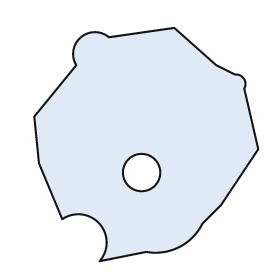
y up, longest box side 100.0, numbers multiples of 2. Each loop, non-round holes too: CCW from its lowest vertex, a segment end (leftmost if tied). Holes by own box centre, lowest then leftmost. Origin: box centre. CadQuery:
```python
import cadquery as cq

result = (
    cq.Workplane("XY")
    .moveTo(-20.0, -50.0)
    .lineTo(0.0, -46.0)
    .threePointArc((14.0, -44.0), (24.0, -34.0))
    .lineTo(32.0, -26.0)
    .lineTo(48.0, -2.0)
    .lineTo(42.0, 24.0)
    .threePointArc((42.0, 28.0), (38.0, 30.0))
    .lineTo(30.0, 34.0)
    .lineTo(12.0, 50.0)
    .lineTo(-16.0, 46.0)
    .threePointArc((-28.0, 46.0), (-30.0, 34.0))
    .lineTo(-48.0, 12.0)
    .lineTo(-46.0, -8.0)
    .lineTo(-36.0, -32.0)
    .threePointArc((-20.0, -34.0), (-20.0, -50.0))
    .close()
    .moveTo(-2.0, -12.0)
    .circle(8.0)
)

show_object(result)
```